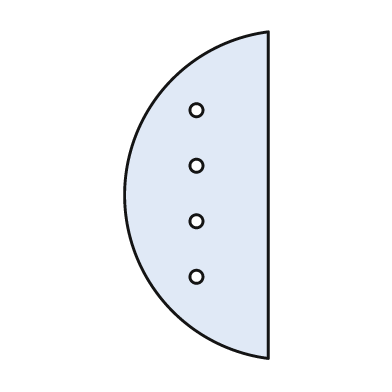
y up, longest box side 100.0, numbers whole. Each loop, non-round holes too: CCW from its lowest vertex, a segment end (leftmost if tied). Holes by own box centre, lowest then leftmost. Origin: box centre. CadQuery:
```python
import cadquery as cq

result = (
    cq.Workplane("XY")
    .moveTo(22.0, -50.0)
    .lineTo(22.0, 50.0)
    .threePointArc((-22.0, 0.0), (22.0, -50.0))
    .close()
    .moveTo(0.0, -25.0)
    .circle(2.0)
    .moveTo(0.0, -8.0)
    .circle(2.0)
    .moveTo(0.0, 9.0)
    .circle(2.0)
    .moveTo(0.0, 26.0)
    .circle(2.0)
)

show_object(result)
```